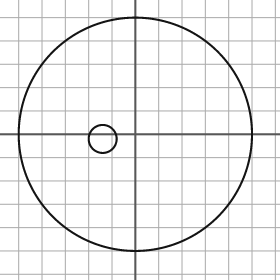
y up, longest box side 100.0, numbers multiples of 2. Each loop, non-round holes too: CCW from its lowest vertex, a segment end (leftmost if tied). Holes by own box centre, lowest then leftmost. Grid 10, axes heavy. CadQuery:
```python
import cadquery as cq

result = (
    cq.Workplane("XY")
    .moveTo(0.0, 0.0)
    .circle(50.0)
    .moveTo(-14.0, -2.0)
    .circle(6.0)
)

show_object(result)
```